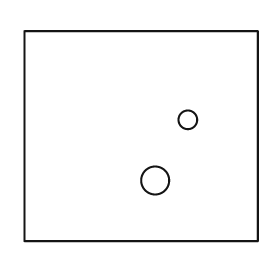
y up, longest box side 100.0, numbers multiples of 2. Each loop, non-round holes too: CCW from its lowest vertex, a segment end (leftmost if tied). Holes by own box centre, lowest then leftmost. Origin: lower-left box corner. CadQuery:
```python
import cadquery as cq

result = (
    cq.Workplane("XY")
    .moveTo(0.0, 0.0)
    .lineTo(100.0, 0.0)
    .lineTo(100.0, 90.0)
    .lineTo(0.0, 90.0)
    .close()
    .moveTo(56.0, 26.0)
    .circle(6.0)
    .moveTo(70.0, 52.0)
    .circle(4.0)
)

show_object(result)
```